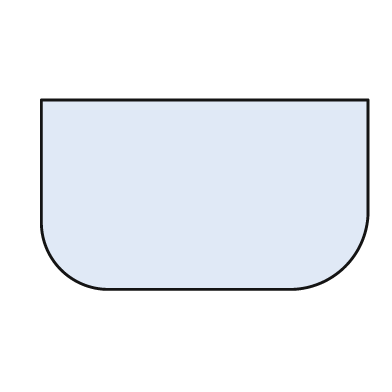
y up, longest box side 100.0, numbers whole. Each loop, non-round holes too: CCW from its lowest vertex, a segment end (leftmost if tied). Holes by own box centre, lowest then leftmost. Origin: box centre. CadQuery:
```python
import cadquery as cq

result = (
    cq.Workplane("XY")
    .moveTo(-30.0, -29.0)
    .lineTo(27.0, -29.0)
    .threePointArc((43.0, -22.0), (50.0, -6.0))
    .lineTo(50.0, 29.0)
    .lineTo(-50.0, 29.0)
    .lineTo(-50.0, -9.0)
    .threePointArc((-44.0, -23.0), (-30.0, -29.0))
    .close()
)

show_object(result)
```